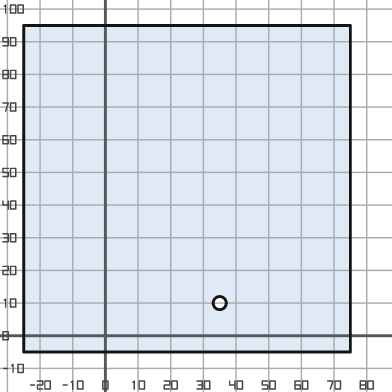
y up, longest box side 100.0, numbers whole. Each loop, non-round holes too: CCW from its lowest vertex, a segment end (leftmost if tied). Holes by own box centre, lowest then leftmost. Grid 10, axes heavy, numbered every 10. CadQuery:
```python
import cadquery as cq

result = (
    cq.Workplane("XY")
    .moveTo(-25.0, -5.0)
    .lineTo(75.0, -5.0)
    .lineTo(75.0, 95.0)
    .lineTo(-25.0, 95.0)
    .close()
    .moveTo(35.0, 10.0)
    .circle(2.0)
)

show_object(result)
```